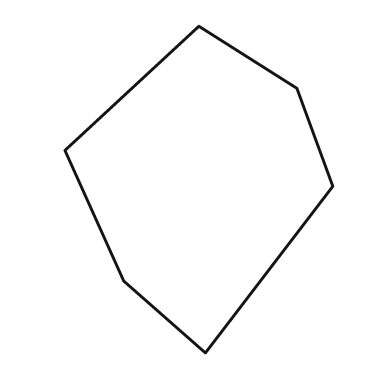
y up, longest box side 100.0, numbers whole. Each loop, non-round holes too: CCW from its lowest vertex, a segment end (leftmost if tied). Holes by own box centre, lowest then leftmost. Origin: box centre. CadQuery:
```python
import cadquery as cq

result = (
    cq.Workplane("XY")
    .moveTo(2.0, -50.0)
    .lineTo(41.0, 1.0)
    .lineTo(30.0, 31.0)
    .lineTo(0.0, 50.0)
    .lineTo(-41.0, 12.0)
    .lineTo(-23.0, -28.0)
    .close()
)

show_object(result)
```